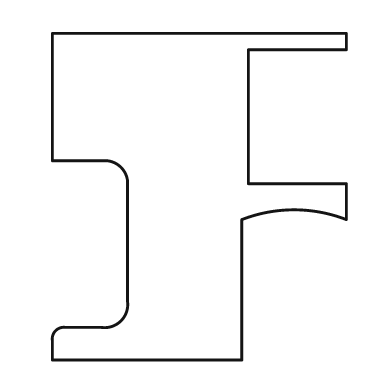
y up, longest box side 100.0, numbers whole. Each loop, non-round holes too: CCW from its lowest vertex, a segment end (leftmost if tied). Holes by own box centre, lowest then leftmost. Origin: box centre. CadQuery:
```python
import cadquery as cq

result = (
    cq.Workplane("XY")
    .moveTo(-45.0, -50.0)
    .lineTo(13.0, -50.0)
    .lineTo(13.0, -7.0)
    .threePointArc((29.0, -4.0), (45.0, -7.0))
    .lineTo(45.0, 4.0)
    .lineTo(15.0, 4.0)
    .lineTo(15.0, 45.0)
    .lineTo(45.0, 45.0)
    .lineTo(45.0, 50.0)
    .lineTo(-45.0, 50.0)
    .lineTo(-45.0, 11.0)
    .lineTo(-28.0, 11.0)
    .threePointArc((-24.0, 9.0), (-22.0, 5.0))
    .lineTo(-22.0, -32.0)
    .threePointArc((-24.0, -38.0), (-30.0, -40.0))
    .lineTo(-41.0, -40.0)
    .threePointArc((-44.0, -41.0), (-45.0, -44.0))
    .close()
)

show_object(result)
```